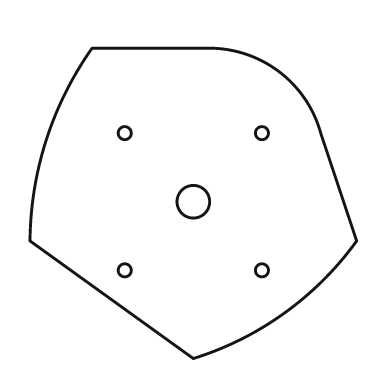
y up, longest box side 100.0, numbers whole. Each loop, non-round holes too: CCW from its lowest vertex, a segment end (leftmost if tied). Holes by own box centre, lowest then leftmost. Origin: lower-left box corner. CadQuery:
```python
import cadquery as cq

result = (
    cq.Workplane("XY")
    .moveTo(50.0, 0.0)
    .threePointArc((78.0, 14.0), (100.0, 36.0))
    .lineTo(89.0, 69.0)
    .threePointArc((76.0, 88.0), (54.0, 95.0))
    .lineTo(19.0, 95.0)
    .threePointArc((5.0, 67.0), (0.0, 36.0))
    .close()
    .moveTo(29.0, 27.0)
    .circle(2.0)
    .moveTo(71.0, 27.0)
    .circle(2.0)
    .moveTo(50.0, 48.0)
    .circle(5.0)
    .moveTo(29.0, 69.0)
    .circle(2.0)
    .moveTo(71.0, 69.0)
    .circle(2.0)
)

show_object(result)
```